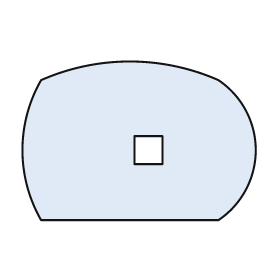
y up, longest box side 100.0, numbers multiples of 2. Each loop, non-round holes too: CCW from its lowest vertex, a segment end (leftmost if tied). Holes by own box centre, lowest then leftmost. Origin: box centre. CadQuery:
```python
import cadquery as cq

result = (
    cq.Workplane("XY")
    .moveTo(-42.0, -34.0)
    .lineTo(34.0, -34.0)
    .threePointArc((50.0, -4.0), (34.0, 26.0))
    .threePointArc((-4.0, 34.0), (-42.0, 26.0))
    .threePointArc((-50.0, -4.0), (-42.0, -34.0))
    .close()
    .moveTo(-2.0, -10.0)
    .lineTo(10.0, -10.0)
    .lineTo(10.0, 2.0)
    .lineTo(-2.0, 2.0)
    .close()
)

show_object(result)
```